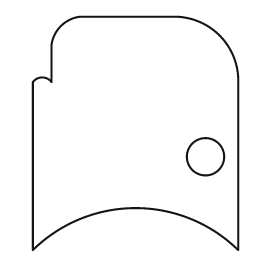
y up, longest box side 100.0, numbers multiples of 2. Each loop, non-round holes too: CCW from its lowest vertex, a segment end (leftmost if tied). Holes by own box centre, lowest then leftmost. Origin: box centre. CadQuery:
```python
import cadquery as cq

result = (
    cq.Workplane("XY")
    .moveTo(-44.0, -50.0)
    .threePointArc((0.0, -32.0), (44.0, -50.0))
    .lineTo(44.0, 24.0)
    .threePointArc((36.0, 42.0), (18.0, 50.0))
    .lineTo(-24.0, 50.0)
    .threePointArc((-32.0, 46.0), (-36.0, 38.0))
    .lineTo(-36.0, 22.0)
    .threePointArc((-40.0, 24.0), (-44.0, 22.0))
    .close()
    .moveTo(30.0, -10.0)
    .circle(8.0)
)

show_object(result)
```